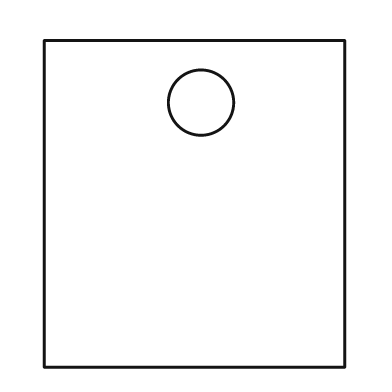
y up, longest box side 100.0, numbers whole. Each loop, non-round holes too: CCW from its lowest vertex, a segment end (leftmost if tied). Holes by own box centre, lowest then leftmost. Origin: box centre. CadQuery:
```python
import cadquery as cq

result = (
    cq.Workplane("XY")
    .moveTo(-46.0, -50.0)
    .lineTo(46.0, -50.0)
    .lineTo(46.0, 50.0)
    .lineTo(-46.0, 50.0)
    .close()
    .moveTo(2.0, 31.0)
    .circle(10.0)
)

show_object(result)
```